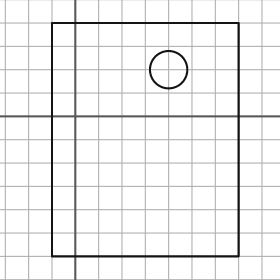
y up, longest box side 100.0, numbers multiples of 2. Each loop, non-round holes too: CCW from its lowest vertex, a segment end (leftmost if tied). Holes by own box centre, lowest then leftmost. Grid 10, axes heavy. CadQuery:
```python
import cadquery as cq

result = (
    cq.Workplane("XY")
    .moveTo(-10.0, -60.0)
    .lineTo(70.0, -60.0)
    .lineTo(70.0, 40.0)
    .lineTo(-10.0, 40.0)
    .close()
    .moveTo(40.0, 20.0)
    .circle(8.0)
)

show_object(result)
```